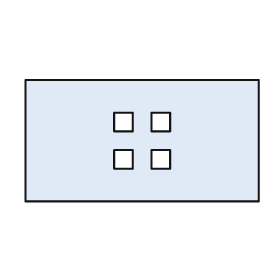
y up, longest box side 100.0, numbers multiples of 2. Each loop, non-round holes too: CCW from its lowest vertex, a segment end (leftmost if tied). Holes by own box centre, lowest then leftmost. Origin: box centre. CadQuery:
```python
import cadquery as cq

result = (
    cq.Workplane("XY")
    .moveTo(-50.0, -26.0)
    .lineTo(50.0, -26.0)
    .lineTo(50.0, 26.0)
    .lineTo(-50.0, 26.0)
    .close()
    .moveTo(-12.0, -12.0)
    .lineTo(-4.0, -12.0)
    .lineTo(-4.0, -4.0)
    .lineTo(-12.0, -4.0)
    .close()
    .moveTo(4.0, -12.0)
    .lineTo(12.0, -12.0)
    .lineTo(12.0, -4.0)
    .lineTo(4.0, -4.0)
    .close()
    .moveTo(-12.0, 4.0)
    .lineTo(-4.0, 4.0)
    .lineTo(-4.0, 12.0)
    .lineTo(-12.0, 12.0)
    .close()
    .moveTo(4.0, 4.0)
    .lineTo(12.0, 4.0)
    .lineTo(12.0, 12.0)
    .lineTo(4.0, 12.0)
    .close()
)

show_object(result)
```